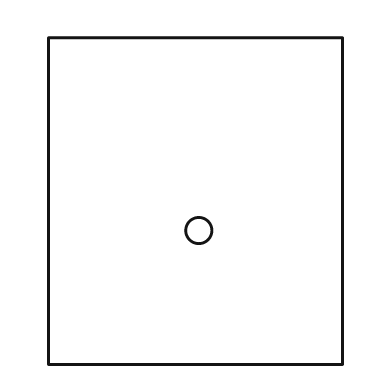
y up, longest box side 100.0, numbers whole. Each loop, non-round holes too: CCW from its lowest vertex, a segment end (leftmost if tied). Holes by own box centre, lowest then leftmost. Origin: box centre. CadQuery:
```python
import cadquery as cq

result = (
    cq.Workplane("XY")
    .moveTo(-45.0, -50.0)
    .lineTo(45.0, -50.0)
    .lineTo(45.0, 50.0)
    .lineTo(-45.0, 50.0)
    .close()
    .moveTo(1.0, -9.0)
    .circle(4.0)
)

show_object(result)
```